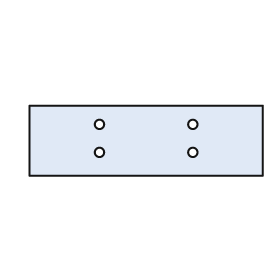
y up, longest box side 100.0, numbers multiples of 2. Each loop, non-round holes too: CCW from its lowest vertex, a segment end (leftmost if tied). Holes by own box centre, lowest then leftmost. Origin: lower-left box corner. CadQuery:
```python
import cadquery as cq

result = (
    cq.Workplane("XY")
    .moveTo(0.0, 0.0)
    .lineTo(100.0, 0.0)
    .lineTo(100.0, 30.0)
    .lineTo(0.0, 30.0)
    .close()
    .moveTo(30.0, 10.0)
    .circle(2.0)
    .moveTo(70.0, 10.0)
    .circle(2.0)
    .moveTo(30.0, 22.0)
    .circle(2.0)
    .moveTo(70.0, 22.0)
    .circle(2.0)
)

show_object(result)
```